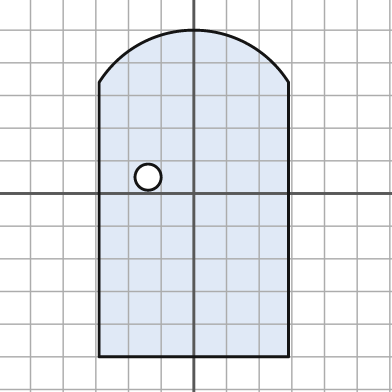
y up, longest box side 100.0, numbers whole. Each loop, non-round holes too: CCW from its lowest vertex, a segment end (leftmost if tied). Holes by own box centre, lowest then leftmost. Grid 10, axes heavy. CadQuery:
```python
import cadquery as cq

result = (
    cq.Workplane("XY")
    .moveTo(-29.0, -50.0)
    .lineTo(29.0, -50.0)
    .lineTo(29.0, 34.0)
    .threePointArc((0.0, 50.0), (-29.0, 34.0))
    .close()
    .moveTo(-14.0, 5.0)
    .circle(4.0)
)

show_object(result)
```